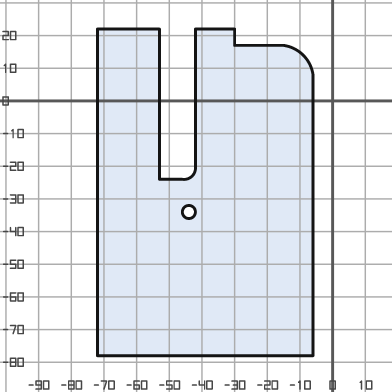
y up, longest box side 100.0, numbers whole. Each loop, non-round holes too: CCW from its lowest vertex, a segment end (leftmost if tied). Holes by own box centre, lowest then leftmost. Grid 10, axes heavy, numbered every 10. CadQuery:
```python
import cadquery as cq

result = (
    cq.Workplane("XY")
    .moveTo(-72.0, -78.0)
    .lineTo(-6.0, -78.0)
    .lineTo(-6.0, 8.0)
    .threePointArc((-9.0, 14.0), (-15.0, 17.0))
    .lineTo(-30.0, 17.0)
    .lineTo(-30.0, 22.0)
    .lineTo(-42.0, 22.0)
    .lineTo(-42.0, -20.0)
    .threePointArc((-43.0, -23.0), (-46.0, -24.0))
    .lineTo(-53.0, -24.0)
    .lineTo(-53.0, 22.0)
    .lineTo(-72.0, 22.0)
    .close()
    .moveTo(-44.0, -34.0)
    .circle(2.0)
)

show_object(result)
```